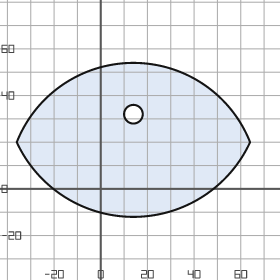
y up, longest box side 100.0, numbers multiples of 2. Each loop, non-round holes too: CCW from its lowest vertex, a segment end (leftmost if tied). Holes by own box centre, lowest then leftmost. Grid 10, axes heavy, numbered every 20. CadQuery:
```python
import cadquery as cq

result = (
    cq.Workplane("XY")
    .moveTo(-36.0, 20.0)
    .threePointArc((14.0, -12.0), (64.0, 20.0))
    .threePointArc((14.0, 54.0), (-36.0, 20.0))
    .close()
    .moveTo(14.0, 32.0)
    .circle(4.0)
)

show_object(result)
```